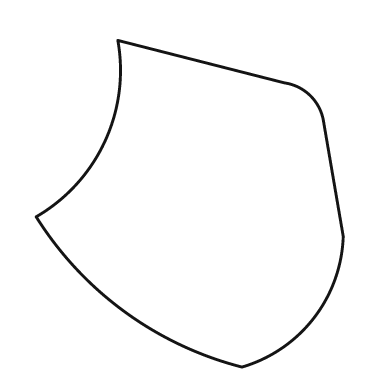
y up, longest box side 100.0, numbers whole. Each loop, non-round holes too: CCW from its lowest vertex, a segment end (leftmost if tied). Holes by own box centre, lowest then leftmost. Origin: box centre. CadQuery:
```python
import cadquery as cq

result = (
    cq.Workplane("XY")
    .moveTo(16.0, -50.0)
    .threePointArc((38.0, -35.0), (47.0, -10.0))
    .lineTo(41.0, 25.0)
    .threePointArc((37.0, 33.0), (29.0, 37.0))
    .lineTo(-22.0, 50.0)
    .threePointArc((-26.0, 19.0), (-47.0, -4.0))
    .threePointArc((-20.0, -33.0), (16.0, -50.0))
    .close()
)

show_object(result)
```